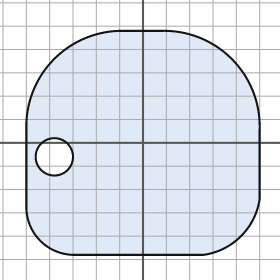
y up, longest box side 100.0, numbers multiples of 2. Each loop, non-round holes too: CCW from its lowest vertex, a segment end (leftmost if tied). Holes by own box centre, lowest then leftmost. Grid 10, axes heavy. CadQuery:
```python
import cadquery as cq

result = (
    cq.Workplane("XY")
    .moveTo(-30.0, -48.0)
    .lineTo(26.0, -48.0)
    .threePointArc((42.0, -40.0), (50.0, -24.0))
    .lineTo(50.0, 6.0)
    .threePointArc((38.0, 36.0), (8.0, 48.0))
    .lineTo(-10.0, 48.0)
    .threePointArc((-38.0, 36.0), (-50.0, 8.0))
    .lineTo(-50.0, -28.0)
    .threePointArc((-44.0, -42.0), (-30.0, -48.0))
    .close()
    .moveTo(-38.0, -6.0)
    .circle(8.0)
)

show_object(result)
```